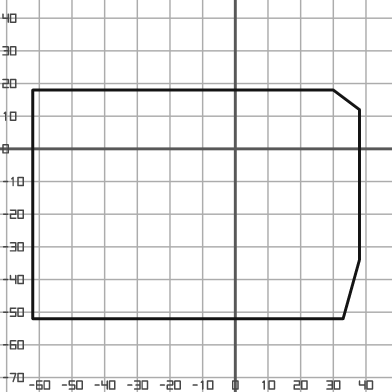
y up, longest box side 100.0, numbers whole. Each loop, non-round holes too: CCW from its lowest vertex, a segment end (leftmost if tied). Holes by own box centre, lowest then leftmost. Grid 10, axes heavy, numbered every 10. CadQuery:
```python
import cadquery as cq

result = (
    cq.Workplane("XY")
    .moveTo(-62.0, -52.0)
    .lineTo(33.0, -52.0)
    .lineTo(38.0, -34.0)
    .lineTo(38.0, 12.0)
    .lineTo(30.0, 18.0)
    .lineTo(-62.0, 18.0)
    .close()
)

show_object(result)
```